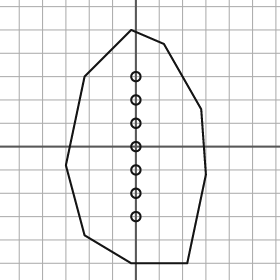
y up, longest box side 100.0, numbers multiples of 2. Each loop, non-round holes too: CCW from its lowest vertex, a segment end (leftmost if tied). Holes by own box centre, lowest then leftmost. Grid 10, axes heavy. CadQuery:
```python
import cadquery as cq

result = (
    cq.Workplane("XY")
    .moveTo(-2.0, -50.0)
    .lineTo(22.0, -50.0)
    .lineTo(30.0, -12.0)
    .lineTo(28.0, 16.0)
    .lineTo(12.0, 44.0)
    .lineTo(-2.0, 50.0)
    .lineTo(-22.0, 30.0)
    .lineTo(-30.0, -8.0)
    .lineTo(-22.0, -38.0)
    .close()
    .moveTo(0.0, -30.0)
    .circle(2.0)
    .moveTo(0.0, -20.0)
    .circle(2.0)
    .moveTo(0.0, -10.0)
    .circle(2.0)
    .moveTo(0.0, 0.0)
    .circle(2.0)
    .moveTo(0.0, 10.0)
    .circle(2.0)
    .moveTo(0.0, 20.0)
    .circle(2.0)
    .moveTo(0.0, 30.0)
    .circle(2.0)
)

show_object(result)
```